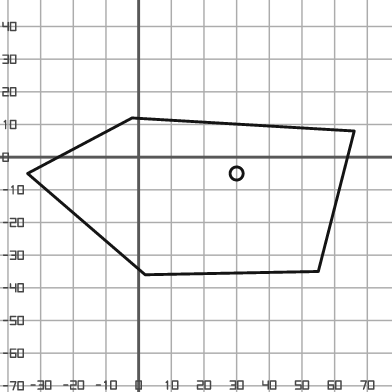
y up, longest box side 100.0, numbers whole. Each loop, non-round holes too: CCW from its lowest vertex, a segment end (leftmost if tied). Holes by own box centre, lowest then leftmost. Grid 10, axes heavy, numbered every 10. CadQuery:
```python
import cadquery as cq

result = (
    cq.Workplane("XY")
    .moveTo(2.0, -36.0)
    .lineTo(55.0, -35.0)
    .lineTo(66.0, 8.0)
    .lineTo(-2.0, 12.0)
    .lineTo(-34.0, -5.0)
    .close()
    .moveTo(30.0, -5.0)
    .circle(2.0)
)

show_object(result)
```